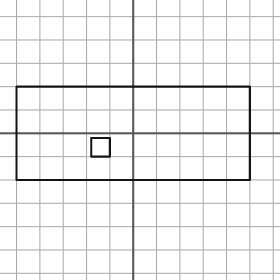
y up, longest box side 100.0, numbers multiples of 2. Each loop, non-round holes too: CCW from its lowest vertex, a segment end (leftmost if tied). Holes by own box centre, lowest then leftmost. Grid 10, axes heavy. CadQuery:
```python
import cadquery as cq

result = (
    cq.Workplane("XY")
    .moveTo(-50.0, -20.0)
    .lineTo(50.0, -20.0)
    .lineTo(50.0, 20.0)
    .lineTo(-50.0, 20.0)
    .close()
    .moveTo(-18.0, -10.0)
    .lineTo(-10.0, -10.0)
    .lineTo(-10.0, -2.0)
    .lineTo(-18.0, -2.0)
    .close()
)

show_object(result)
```